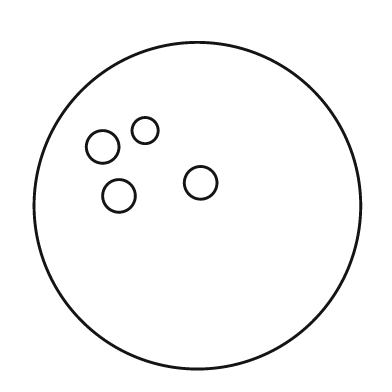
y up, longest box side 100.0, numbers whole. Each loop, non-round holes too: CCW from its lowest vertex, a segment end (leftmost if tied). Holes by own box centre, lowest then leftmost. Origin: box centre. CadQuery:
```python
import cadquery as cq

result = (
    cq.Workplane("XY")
    .moveTo(0.0, 0.0)
    .circle(50.0)
    .moveTo(-24.0, 3.0)
    .circle(5.0)
    .moveTo(1.0, 7.0)
    .circle(5.0)
    .moveTo(-29.0, 18.0)
    .circle(5.0)
    .moveTo(-16.0, 23.0)
    .circle(4.0)
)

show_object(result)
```